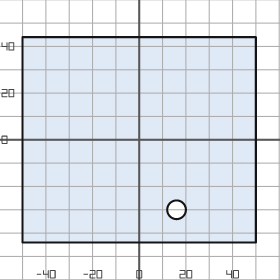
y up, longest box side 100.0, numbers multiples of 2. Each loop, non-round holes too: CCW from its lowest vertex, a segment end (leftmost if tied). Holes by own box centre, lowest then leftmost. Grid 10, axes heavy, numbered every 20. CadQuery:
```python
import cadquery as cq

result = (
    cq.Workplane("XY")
    .moveTo(-50.0, -44.0)
    .lineTo(50.0, -44.0)
    .lineTo(50.0, 44.0)
    .lineTo(-50.0, 44.0)
    .close()
    .moveTo(16.0, -30.0)
    .circle(4.0)
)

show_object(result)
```